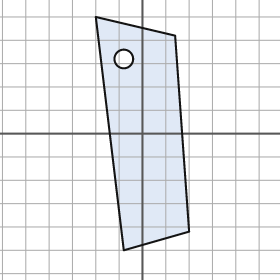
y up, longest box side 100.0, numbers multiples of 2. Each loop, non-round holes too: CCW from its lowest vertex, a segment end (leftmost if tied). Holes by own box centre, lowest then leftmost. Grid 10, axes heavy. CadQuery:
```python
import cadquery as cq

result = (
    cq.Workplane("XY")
    .moveTo(-8.0, -50.0)
    .lineTo(20.0, -42.0)
    .lineTo(14.0, 42.0)
    .lineTo(-20.0, 50.0)
    .close()
    .moveTo(-8.0, 32.0)
    .circle(4.0)
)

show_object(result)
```